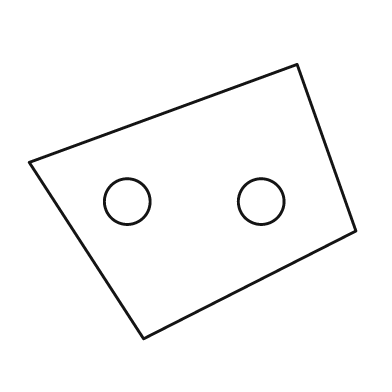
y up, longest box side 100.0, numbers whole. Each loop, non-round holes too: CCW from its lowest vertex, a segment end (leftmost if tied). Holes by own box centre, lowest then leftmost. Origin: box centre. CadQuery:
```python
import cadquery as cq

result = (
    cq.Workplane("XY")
    .moveTo(-15.0, -42.0)
    .lineTo(50.0, -9.0)
    .lineTo(32.0, 42.0)
    .lineTo(-50.0, 12.0)
    .close()
    .moveTo(-20.0, 0.0)
    .circle(7.0)
    .moveTo(21.0, 0.0)
    .circle(7.0)
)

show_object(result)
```